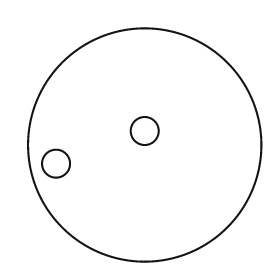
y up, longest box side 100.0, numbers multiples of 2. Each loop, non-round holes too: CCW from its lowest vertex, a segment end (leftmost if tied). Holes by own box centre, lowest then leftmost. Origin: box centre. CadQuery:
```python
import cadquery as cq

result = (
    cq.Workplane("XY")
    .moveTo(0.0, 0.0)
    .circle(50.0)
    .moveTo(-38.0, -8.0)
    .circle(6.0)
    .moveTo(0.0, 6.0)
    .circle(6.0)
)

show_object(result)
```